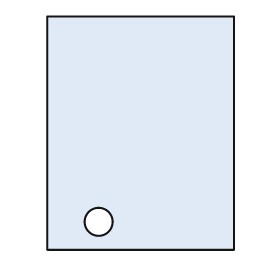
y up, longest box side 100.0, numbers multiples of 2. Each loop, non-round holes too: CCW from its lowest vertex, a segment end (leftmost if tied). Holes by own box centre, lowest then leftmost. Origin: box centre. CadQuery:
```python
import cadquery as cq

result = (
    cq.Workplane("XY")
    .moveTo(-40.0, -50.0)
    .lineTo(40.0, -50.0)
    .lineTo(40.0, 50.0)
    .lineTo(-40.0, 50.0)
    .close()
    .moveTo(-18.0, -38.0)
    .circle(6.0)
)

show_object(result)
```